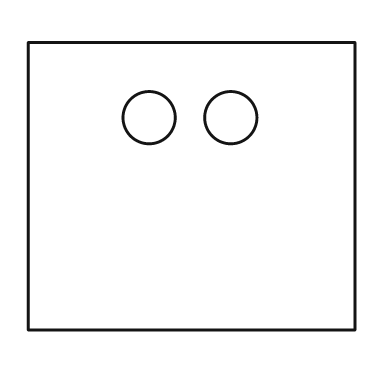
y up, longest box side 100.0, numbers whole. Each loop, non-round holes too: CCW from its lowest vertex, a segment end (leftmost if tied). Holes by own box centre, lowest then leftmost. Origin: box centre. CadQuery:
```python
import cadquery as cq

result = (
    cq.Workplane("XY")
    .moveTo(-50.0, -44.0)
    .lineTo(50.0, -44.0)
    .lineTo(50.0, 44.0)
    .lineTo(-50.0, 44.0)
    .close()
    .moveTo(-13.0, 21.0)
    .circle(8.0)
    .moveTo(12.0, 21.0)
    .circle(8.0)
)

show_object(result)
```